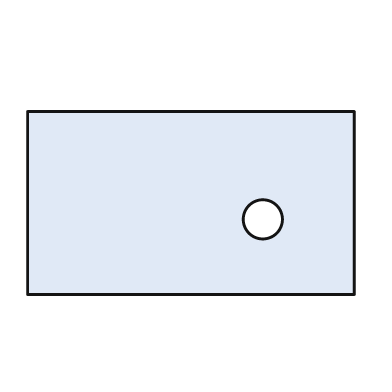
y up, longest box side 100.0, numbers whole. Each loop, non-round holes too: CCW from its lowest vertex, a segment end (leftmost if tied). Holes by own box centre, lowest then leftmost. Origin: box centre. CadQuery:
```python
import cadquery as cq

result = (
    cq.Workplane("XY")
    .moveTo(-50.0, -28.0)
    .lineTo(50.0, -28.0)
    .lineTo(50.0, 28.0)
    .lineTo(-50.0, 28.0)
    .close()
    .moveTo(22.0, -5.0)
    .circle(6.0)
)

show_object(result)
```